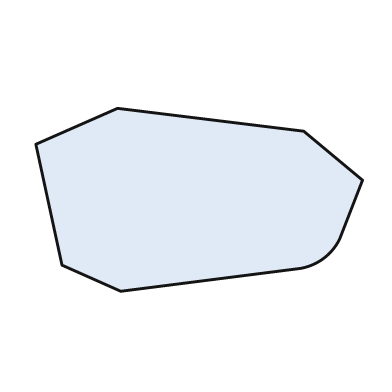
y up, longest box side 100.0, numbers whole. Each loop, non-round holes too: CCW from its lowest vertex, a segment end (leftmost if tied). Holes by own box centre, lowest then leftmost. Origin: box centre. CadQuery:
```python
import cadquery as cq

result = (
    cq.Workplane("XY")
    .moveTo(-24.0, -28.0)
    .lineTo(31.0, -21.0)
    .threePointArc((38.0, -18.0), (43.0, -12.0))
    .lineTo(50.0, 6.0)
    .lineTo(32.0, 21.0)
    .lineTo(-25.0, 28.0)
    .lineTo(-50.0, 17.0)
    .lineTo(-42.0, -20.0)
    .close()
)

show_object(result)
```